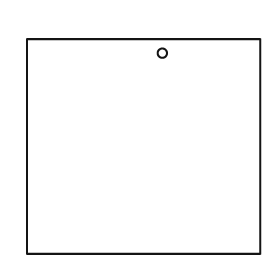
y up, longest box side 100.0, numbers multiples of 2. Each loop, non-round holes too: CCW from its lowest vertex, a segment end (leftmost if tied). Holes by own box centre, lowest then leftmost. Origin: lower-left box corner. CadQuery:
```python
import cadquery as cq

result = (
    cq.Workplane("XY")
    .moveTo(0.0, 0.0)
    .lineTo(100.0, 0.0)
    .lineTo(100.0, 92.0)
    .lineTo(0.0, 92.0)
    .close()
    .moveTo(58.0, 86.0)
    .circle(2.0)
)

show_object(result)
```